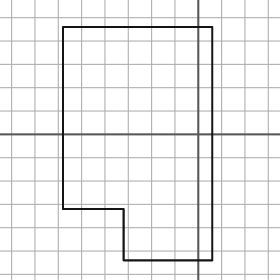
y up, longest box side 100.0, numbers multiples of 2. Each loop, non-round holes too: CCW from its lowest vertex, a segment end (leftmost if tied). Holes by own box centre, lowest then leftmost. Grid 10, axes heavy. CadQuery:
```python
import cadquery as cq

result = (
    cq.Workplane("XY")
    .moveTo(-32.0, -54.0)
    .lineTo(6.0, -54.0)
    .lineTo(6.0, 46.0)
    .lineTo(-58.0, 46.0)
    .lineTo(-58.0, -32.0)
    .lineTo(-32.0, -32.0)
    .close()
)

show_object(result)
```